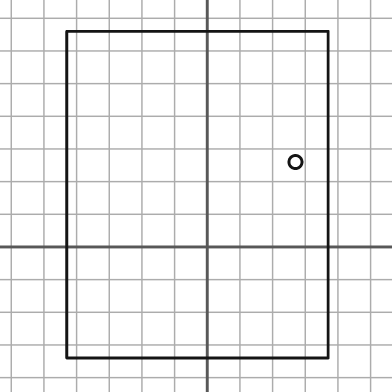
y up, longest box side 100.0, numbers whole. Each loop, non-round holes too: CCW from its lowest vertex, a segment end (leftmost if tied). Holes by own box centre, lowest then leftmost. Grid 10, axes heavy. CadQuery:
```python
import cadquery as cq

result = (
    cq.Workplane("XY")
    .moveTo(-43.0, -34.0)
    .lineTo(37.0, -34.0)
    .lineTo(37.0, 66.0)
    .lineTo(-43.0, 66.0)
    .close()
    .moveTo(27.0, 26.0)
    .circle(2.0)
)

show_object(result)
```